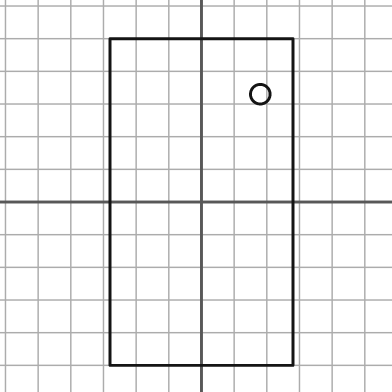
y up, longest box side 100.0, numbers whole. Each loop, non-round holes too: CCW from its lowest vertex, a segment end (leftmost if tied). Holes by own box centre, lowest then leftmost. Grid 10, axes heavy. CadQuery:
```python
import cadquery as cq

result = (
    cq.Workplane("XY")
    .moveTo(-28.0, -50.0)
    .lineTo(28.0, -50.0)
    .lineTo(28.0, 50.0)
    .lineTo(-28.0, 50.0)
    .close()
    .moveTo(18.0, 33.0)
    .circle(3.0)
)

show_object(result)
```